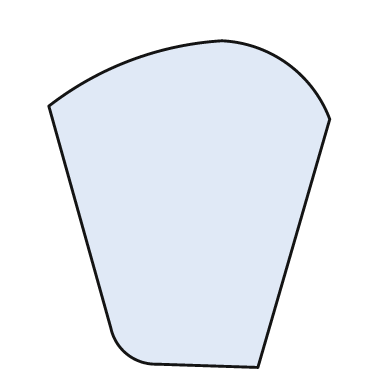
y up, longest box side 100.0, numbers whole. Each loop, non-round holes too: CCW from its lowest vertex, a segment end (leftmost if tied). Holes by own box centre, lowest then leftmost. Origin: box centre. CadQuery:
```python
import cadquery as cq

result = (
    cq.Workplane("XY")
    .moveTo(21.0, -50.0)
    .lineTo(43.0, 26.0)
    .threePointArc((30.0, 43.0), (10.0, 50.0))
    .threePointArc((-18.0, 44.0), (-43.0, 30.0))
    .lineTo(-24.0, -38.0)
    .threePointArc((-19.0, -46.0), (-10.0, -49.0))
    .close()
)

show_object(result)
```